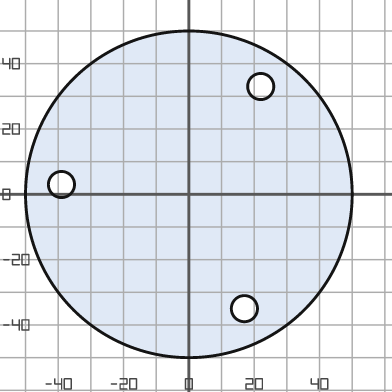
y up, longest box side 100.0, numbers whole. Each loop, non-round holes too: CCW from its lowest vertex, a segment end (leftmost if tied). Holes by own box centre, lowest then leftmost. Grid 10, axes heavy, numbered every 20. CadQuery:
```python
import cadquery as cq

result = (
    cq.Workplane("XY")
    .moveTo(0.0, 0.0)
    .circle(50.0)
    .moveTo(17.0, -35.0)
    .circle(4.0)
    .moveTo(-39.0, 3.0)
    .circle(4.0)
    .moveTo(22.0, 33.0)
    .circle(4.0)
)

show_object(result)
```